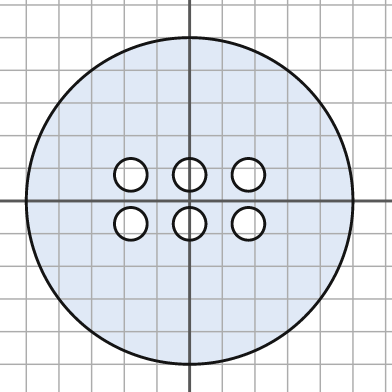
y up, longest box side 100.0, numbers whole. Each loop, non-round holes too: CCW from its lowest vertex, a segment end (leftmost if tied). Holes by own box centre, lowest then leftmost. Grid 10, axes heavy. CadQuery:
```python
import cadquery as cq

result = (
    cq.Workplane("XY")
    .moveTo(0.0, 0.0)
    .circle(50.0)
    .moveTo(-18.0, -7.0)
    .circle(5.0)
    .moveTo(0.0, -7.0)
    .circle(5.0)
    .moveTo(18.0, -7.0)
    .circle(5.0)
    .moveTo(-18.0, 8.0)
    .circle(5.0)
    .moveTo(0.0, 8.0)
    .circle(5.0)
    .moveTo(18.0, 8.0)
    .circle(5.0)
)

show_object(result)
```